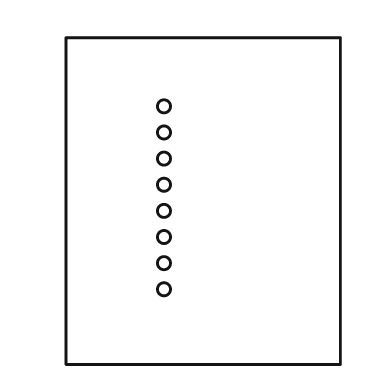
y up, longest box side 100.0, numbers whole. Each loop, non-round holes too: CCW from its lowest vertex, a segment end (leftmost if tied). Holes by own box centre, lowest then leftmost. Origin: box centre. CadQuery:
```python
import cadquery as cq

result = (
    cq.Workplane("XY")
    .moveTo(-42.0, -50.0)
    .lineTo(42.0, -50.0)
    .lineTo(42.0, 50.0)
    .lineTo(-42.0, 50.0)
    .close()
    .moveTo(-12.0, -27.0)
    .circle(2.0)
    .moveTo(-12.0, -19.0)
    .circle(2.0)
    .moveTo(-12.0, -11.0)
    .circle(2.0)
    .moveTo(-12.0, -3.0)
    .circle(2.0)
    .moveTo(-12.0, 5.0)
    .circle(2.0)
    .moveTo(-12.0, 13.0)
    .circle(2.0)
    .moveTo(-12.0, 21.0)
    .circle(2.0)
    .moveTo(-12.0, 29.0)
    .circle(2.0)
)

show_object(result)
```